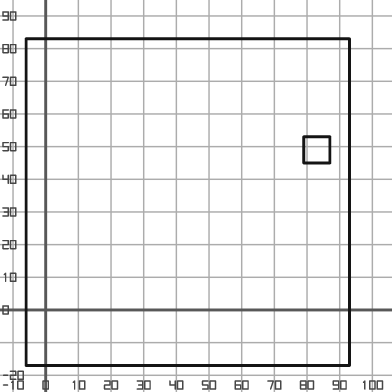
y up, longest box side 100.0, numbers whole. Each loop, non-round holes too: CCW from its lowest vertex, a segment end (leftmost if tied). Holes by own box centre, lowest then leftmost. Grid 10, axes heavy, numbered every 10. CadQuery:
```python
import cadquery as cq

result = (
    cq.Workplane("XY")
    .moveTo(-6.0, -17.0)
    .lineTo(93.0, -17.0)
    .lineTo(93.0, 83.0)
    .lineTo(-6.0, 83.0)
    .close()
    .moveTo(79.0, 45.0)
    .lineTo(87.0, 45.0)
    .lineTo(87.0, 53.0)
    .lineTo(79.0, 53.0)
    .close()
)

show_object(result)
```